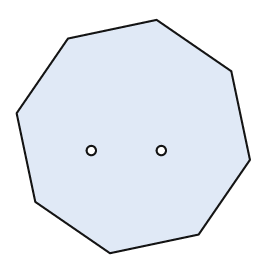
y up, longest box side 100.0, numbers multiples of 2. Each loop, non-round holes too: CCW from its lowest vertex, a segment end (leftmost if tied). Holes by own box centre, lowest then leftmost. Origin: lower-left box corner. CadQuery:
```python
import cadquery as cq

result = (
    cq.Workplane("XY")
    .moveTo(40.0, 0.0)
    .lineTo(78.0, 8.0)
    .lineTo(100.0, 40.0)
    .lineTo(92.0, 78.0)
    .lineTo(60.0, 100.0)
    .lineTo(22.0, 92.0)
    .lineTo(0.0, 60.0)
    .lineTo(8.0, 22.0)
    .close()
    .moveTo(32.0, 44.0)
    .circle(2.0)
    .moveTo(62.0, 44.0)
    .circle(2.0)
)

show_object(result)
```